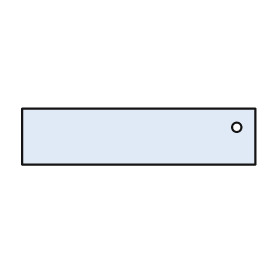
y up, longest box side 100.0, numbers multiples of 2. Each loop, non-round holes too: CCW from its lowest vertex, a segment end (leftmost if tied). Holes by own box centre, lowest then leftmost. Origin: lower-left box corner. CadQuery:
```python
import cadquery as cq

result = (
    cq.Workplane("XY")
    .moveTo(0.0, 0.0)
    .lineTo(100.0, 0.0)
    .lineTo(100.0, 24.0)
    .lineTo(0.0, 24.0)
    .close()
    .moveTo(92.0, 16.0)
    .circle(2.0)
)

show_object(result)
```